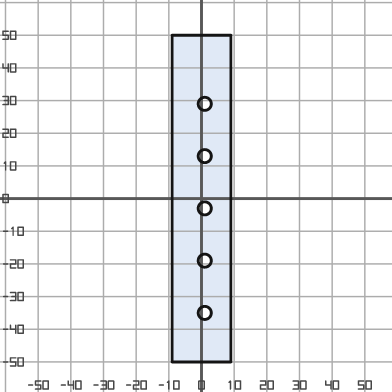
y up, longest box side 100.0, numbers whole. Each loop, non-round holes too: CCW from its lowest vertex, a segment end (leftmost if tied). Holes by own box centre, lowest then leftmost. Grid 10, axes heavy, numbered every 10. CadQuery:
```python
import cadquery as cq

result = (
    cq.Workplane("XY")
    .moveTo(-9.0, -50.0)
    .lineTo(9.0, -50.0)
    .lineTo(9.0, 50.0)
    .lineTo(-9.0, 50.0)
    .close()
    .moveTo(1.0, -35.0)
    .circle(2.0)
    .moveTo(1.0, -19.0)
    .circle(2.0)
    .moveTo(1.0, -3.0)
    .circle(2.0)
    .moveTo(1.0, 13.0)
    .circle(2.0)
    .moveTo(1.0, 29.0)
    .circle(2.0)
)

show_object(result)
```